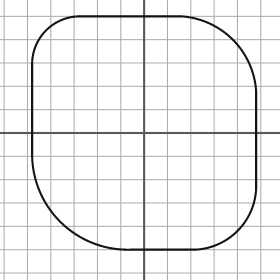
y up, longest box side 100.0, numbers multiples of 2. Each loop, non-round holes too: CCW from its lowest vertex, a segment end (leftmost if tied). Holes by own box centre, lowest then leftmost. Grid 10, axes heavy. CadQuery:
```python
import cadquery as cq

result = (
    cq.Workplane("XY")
    .moveTo(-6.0, -50.0)
    .lineTo(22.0, -50.0)
    .threePointArc((40.0, -42.0), (48.0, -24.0))
    .lineTo(48.0, 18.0)
    .threePointArc((38.0, 40.0), (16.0, 50.0))
    .lineTo(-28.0, 50.0)
    .threePointArc((-42.0, 44.0), (-48.0, 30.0))
    .lineTo(-48.0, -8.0)
    .threePointArc((-36.0, -38.0), (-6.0, -50.0))
    .close()
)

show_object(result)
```